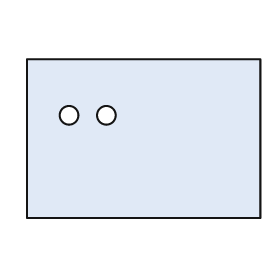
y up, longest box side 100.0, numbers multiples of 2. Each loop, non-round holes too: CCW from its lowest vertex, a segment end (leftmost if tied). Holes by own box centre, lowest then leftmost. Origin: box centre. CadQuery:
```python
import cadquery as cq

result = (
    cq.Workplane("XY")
    .moveTo(-50.0, -34.0)
    .lineTo(50.0, -34.0)
    .lineTo(50.0, 34.0)
    .lineTo(-50.0, 34.0)
    .close()
    .moveTo(-32.0, 10.0)
    .circle(4.0)
    .moveTo(-16.0, 10.0)
    .circle(4.0)
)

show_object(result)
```